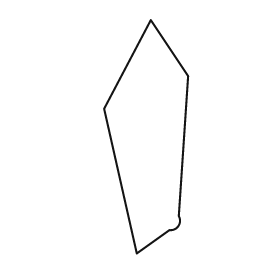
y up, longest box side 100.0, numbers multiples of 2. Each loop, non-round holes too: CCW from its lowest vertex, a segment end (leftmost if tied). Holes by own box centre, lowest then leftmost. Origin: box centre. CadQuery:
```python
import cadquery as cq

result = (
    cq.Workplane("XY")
    .moveTo(-4.0, -50.0)
    .lineTo(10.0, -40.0)
    .threePointArc((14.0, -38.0), (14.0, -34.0))
    .lineTo(18.0, 26.0)
    .lineTo(2.0, 50.0)
    .lineTo(-18.0, 12.0)
    .close()
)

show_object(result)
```